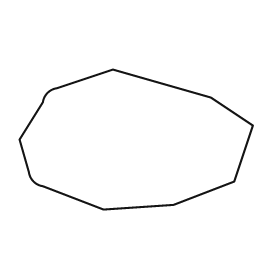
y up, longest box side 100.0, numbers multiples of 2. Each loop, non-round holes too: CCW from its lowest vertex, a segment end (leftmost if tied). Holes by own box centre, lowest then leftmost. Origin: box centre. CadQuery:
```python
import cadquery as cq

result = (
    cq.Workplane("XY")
    .moveTo(-14.0, -30.0)
    .lineTo(16.0, -28.0)
    .lineTo(42.0, -18.0)
    .lineTo(50.0, 6.0)
    .lineTo(32.0, 18.0)
    .lineTo(-10.0, 30.0)
    .lineTo(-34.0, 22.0)
    .threePointArc((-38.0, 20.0), (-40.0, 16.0))
    .lineTo(-50.0, 0.0)
    .lineTo(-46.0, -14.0)
    .threePointArc((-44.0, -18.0), (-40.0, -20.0))
    .close()
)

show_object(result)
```